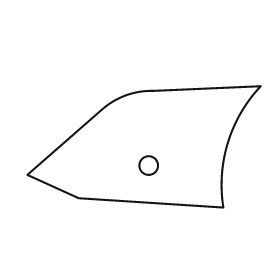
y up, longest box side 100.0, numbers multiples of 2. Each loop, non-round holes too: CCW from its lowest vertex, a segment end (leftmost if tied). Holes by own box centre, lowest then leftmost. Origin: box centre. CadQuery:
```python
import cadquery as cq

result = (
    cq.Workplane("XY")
    .moveTo(34.0, -26.0)
    .threePointArc((36.0, 2.0), (50.0, 26.0))
    .lineTo(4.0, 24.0)
    .threePointArc((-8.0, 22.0), (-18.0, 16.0))
    .lineTo(-50.0, -12.0)
    .lineTo(-28.0, -22.0)
    .close()
    .moveTo(2.0, -8.0)
    .circle(4.0)
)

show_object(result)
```